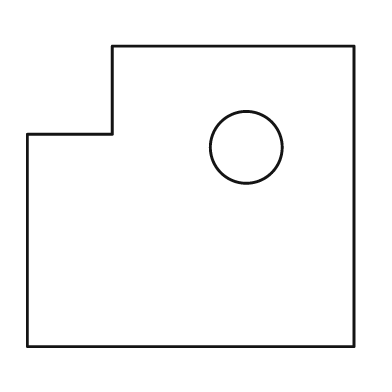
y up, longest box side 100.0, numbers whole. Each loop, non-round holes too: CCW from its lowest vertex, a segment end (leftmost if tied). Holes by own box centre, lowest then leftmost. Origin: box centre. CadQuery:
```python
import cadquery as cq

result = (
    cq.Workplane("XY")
    .moveTo(-50.0, -46.0)
    .lineTo(50.0, -46.0)
    .lineTo(50.0, 46.0)
    .lineTo(-24.0, 46.0)
    .lineTo(-24.0, 19.0)
    .lineTo(-50.0, 19.0)
    .close()
    .moveTo(17.0, 15.0)
    .circle(11.0)
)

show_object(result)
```